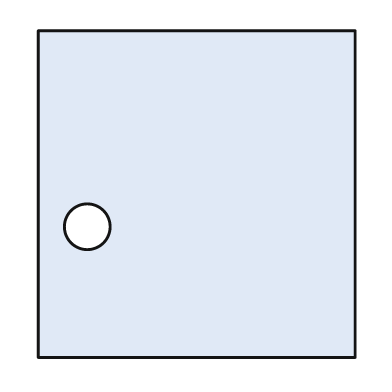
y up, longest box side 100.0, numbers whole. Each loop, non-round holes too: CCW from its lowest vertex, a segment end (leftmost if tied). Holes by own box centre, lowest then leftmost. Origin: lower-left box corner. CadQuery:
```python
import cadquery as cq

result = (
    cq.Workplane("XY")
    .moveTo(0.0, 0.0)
    .lineTo(97.0, 0.0)
    .lineTo(97.0, 100.0)
    .lineTo(0.0, 100.0)
    .close()
    .moveTo(15.0, 40.0)
    .circle(7.0)
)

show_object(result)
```